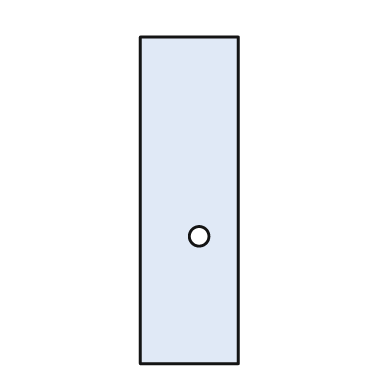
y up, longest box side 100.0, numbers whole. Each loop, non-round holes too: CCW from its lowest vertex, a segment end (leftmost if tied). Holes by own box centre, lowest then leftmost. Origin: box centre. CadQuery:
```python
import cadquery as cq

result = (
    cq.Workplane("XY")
    .moveTo(-15.0, -50.0)
    .lineTo(15.0, -50.0)
    .lineTo(15.0, 50.0)
    .lineTo(-15.0, 50.0)
    .close()
    .moveTo(3.0, -11.0)
    .circle(3.0)
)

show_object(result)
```